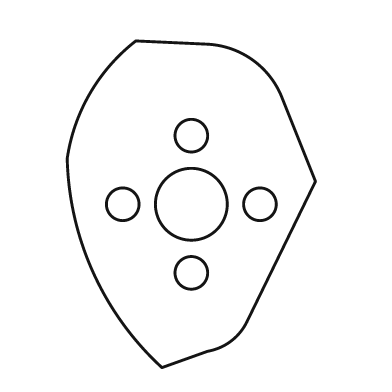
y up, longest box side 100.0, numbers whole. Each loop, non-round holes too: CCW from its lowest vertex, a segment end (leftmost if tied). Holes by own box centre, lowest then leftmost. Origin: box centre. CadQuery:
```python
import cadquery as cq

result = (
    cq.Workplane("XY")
    .moveTo(-9.0, -50.0)
    .lineTo(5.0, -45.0)
    .threePointArc((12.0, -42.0), (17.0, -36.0))
    .lineTo(38.0, 7.0)
    .lineTo(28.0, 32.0)
    .threePointArc((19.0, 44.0), (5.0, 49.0))
    .lineTo(-17.0, 50.0)
    .threePointArc((-31.0, 34.0), (-38.0, 14.0))
    .threePointArc((-30.0, -21.0), (-9.0, -50.0))
    .close()
    .moveTo(0.0, -21.0)
    .circle(5.0)
    .moveTo(-21.0, 0.0)
    .circle(5.0)
    .moveTo(0.0, 0.0)
    .circle(11.0)
    .moveTo(21.0, 0.0)
    .circle(5.0)
    .moveTo(0.0, 21.0)
    .circle(5.0)
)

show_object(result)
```